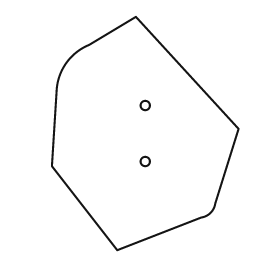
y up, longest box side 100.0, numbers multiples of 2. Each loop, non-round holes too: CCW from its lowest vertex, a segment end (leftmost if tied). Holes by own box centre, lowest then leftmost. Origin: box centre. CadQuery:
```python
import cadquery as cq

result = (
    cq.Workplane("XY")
    .moveTo(-12.0, -50.0)
    .lineTo(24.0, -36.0)
    .threePointArc((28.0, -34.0), (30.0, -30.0))
    .lineTo(40.0, 2.0)
    .lineTo(-4.0, 50.0)
    .lineTo(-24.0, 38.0)
    .threePointArc((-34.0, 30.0), (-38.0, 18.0))
    .lineTo(-40.0, -14.0)
    .close()
    .moveTo(0.0, -12.0)
    .circle(2.0)
    .moveTo(0.0, 12.0)
    .circle(2.0)
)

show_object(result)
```